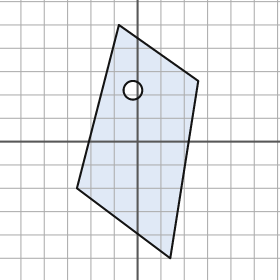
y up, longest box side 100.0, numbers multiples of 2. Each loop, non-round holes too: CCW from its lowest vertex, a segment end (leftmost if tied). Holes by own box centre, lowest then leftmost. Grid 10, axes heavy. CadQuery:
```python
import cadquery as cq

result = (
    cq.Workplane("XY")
    .moveTo(14.0, -50.0)
    .lineTo(26.0, 26.0)
    .lineTo(-8.0, 50.0)
    .lineTo(-26.0, -20.0)
    .close()
    .moveTo(-2.0, 22.0)
    .circle(4.0)
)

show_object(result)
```